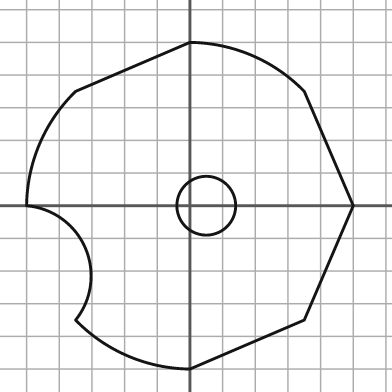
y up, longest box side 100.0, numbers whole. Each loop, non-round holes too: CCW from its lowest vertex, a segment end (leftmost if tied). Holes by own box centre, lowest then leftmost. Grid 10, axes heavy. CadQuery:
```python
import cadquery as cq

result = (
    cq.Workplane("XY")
    .moveTo(0.0, -50.0)
    .lineTo(35.0, -35.0)
    .lineTo(50.0, 0.0)
    .lineTo(35.0, 35.0)
    .threePointArc((19.0, 46.0), (0.0, 50.0))
    .lineTo(-35.0, 35.0)
    .threePointArc((-46.0, 19.0), (-50.0, 0.0))
    .threePointArc((-32.0, -13.0), (-35.0, -35.0))
    .threePointArc((-19.0, -46.0), (0.0, -50.0))
    .close()
    .moveTo(5.0, 0.0)
    .circle(9.0)
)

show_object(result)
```